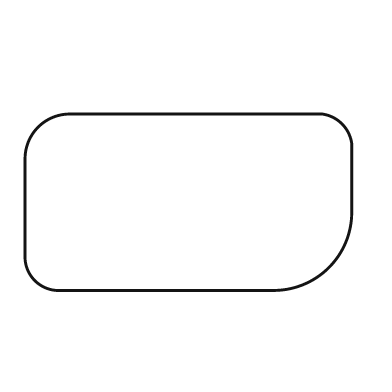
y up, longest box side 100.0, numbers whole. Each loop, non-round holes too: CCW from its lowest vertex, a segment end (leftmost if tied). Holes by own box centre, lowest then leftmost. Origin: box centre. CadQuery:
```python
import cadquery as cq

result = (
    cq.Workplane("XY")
    .moveTo(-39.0, -27.0)
    .lineTo(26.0, -27.0)
    .threePointArc((43.0, -20.0), (50.0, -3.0))
    .lineTo(50.0, 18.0)
    .threePointArc((47.0, 24.0), (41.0, 27.0))
    .lineTo(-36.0, 27.0)
    .threePointArc((-46.0, 23.0), (-50.0, 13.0))
    .lineTo(-50.0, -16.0)
    .threePointArc((-47.0, -24.0), (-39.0, -27.0))
    .close()
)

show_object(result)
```